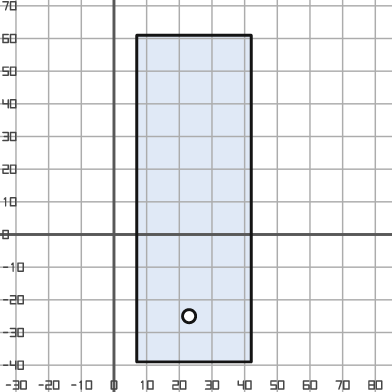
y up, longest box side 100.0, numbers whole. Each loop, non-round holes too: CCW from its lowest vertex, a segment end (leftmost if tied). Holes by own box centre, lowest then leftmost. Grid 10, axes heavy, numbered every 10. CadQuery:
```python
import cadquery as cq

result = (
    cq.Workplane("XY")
    .moveTo(7.0, -39.0)
    .lineTo(42.0, -39.0)
    .lineTo(42.0, 61.0)
    .lineTo(7.0, 61.0)
    .close()
    .moveTo(23.0, -25.0)
    .circle(2.0)
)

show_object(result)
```